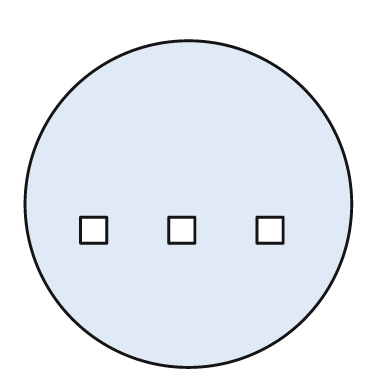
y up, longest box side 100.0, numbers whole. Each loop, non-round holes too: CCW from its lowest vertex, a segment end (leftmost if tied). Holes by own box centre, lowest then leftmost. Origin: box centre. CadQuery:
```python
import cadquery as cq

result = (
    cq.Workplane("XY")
    .moveTo(0.0, 0.0)
    .circle(50.0)
    .moveTo(-33.0, -12.0)
    .lineTo(-25.0, -12.0)
    .lineTo(-25.0, -4.0)
    .lineTo(-33.0, -4.0)
    .close()
    .moveTo(-6.0, -12.0)
    .lineTo(2.0, -12.0)
    .lineTo(2.0, -4.0)
    .lineTo(-6.0, -4.0)
    .close()
    .moveTo(21.0, -12.0)
    .lineTo(29.0, -12.0)
    .lineTo(29.0, -4.0)
    .lineTo(21.0, -4.0)
    .close()
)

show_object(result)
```